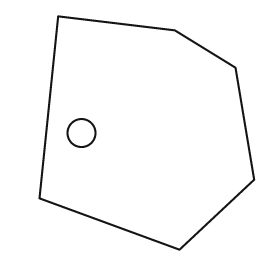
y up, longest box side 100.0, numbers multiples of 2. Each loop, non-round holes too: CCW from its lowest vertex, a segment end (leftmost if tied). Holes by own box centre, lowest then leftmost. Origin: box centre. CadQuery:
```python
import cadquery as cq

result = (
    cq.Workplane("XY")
    .moveTo(14.0, -50.0)
    .lineTo(46.0, -20.0)
    .lineTo(38.0, 28.0)
    .lineTo(12.0, 44.0)
    .lineTo(-38.0, 50.0)
    .lineTo(-46.0, -28.0)
    .close()
    .moveTo(-28.0, 0.0)
    .circle(6.0)
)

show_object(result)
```